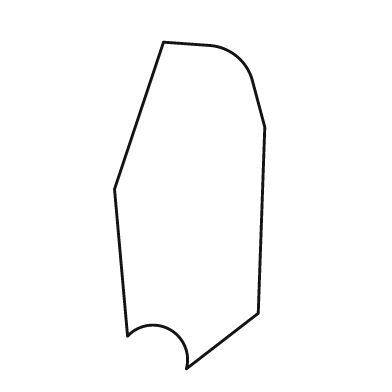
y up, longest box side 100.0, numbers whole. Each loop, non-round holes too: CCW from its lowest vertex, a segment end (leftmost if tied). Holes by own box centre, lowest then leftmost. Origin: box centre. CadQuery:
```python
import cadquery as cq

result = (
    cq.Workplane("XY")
    .moveTo(-1.0, -50.0)
    .lineTo(21.0, -33.0)
    .lineTo(23.0, 24.0)
    .lineTo(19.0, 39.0)
    .threePointArc((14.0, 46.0), (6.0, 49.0))
    .lineTo(-8.0, 50.0)
    .lineTo(-23.0, 5.0)
    .lineTo(-19.0, -40.0)
    .threePointArc((-6.0, -38.0), (-1.0, -50.0))
    .close()
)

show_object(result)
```